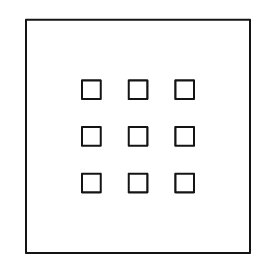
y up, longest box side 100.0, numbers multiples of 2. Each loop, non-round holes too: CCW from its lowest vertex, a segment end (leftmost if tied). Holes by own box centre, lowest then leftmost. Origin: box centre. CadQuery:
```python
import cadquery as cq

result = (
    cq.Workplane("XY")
    .moveTo(-48.0, -50.0)
    .lineTo(48.0, -50.0)
    .lineTo(48.0, 50.0)
    .lineTo(-48.0, 50.0)
    .close()
    .moveTo(-24.0, -24.0)
    .lineTo(-16.0, -24.0)
    .lineTo(-16.0, -16.0)
    .lineTo(-24.0, -16.0)
    .close()
    .moveTo(-4.0, -24.0)
    .lineTo(4.0, -24.0)
    .lineTo(4.0, -16.0)
    .lineTo(-4.0, -16.0)
    .close()
    .moveTo(16.0, -24.0)
    .lineTo(24.0, -24.0)
    .lineTo(24.0, -16.0)
    .lineTo(16.0, -16.0)
    .close()
    .moveTo(-24.0, -4.0)
    .lineTo(-16.0, -4.0)
    .lineTo(-16.0, 4.0)
    .lineTo(-24.0, 4.0)
    .close()
    .moveTo(-4.0, -4.0)
    .lineTo(4.0, -4.0)
    .lineTo(4.0, 4.0)
    .lineTo(-4.0, 4.0)
    .close()
    .moveTo(16.0, -4.0)
    .lineTo(24.0, -4.0)
    .lineTo(24.0, 4.0)
    .lineTo(16.0, 4.0)
    .close()
    .moveTo(-24.0, 16.0)
    .lineTo(-16.0, 16.0)
    .lineTo(-16.0, 24.0)
    .lineTo(-24.0, 24.0)
    .close()
    .moveTo(-4.0, 16.0)
    .lineTo(4.0, 16.0)
    .lineTo(4.0, 24.0)
    .lineTo(-4.0, 24.0)
    .close()
    .moveTo(16.0, 16.0)
    .lineTo(24.0, 16.0)
    .lineTo(24.0, 24.0)
    .lineTo(16.0, 24.0)
    .close()
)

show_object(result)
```